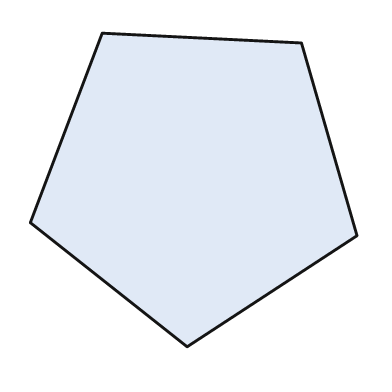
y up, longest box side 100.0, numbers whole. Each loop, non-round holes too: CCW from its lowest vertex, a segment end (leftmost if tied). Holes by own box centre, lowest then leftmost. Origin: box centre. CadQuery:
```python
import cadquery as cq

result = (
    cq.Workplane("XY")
    .moveTo(-2.0, -48.0)
    .lineTo(50.0, -14.0)
    .lineTo(33.0, 45.0)
    .lineTo(-28.0, 48.0)
    .lineTo(-50.0, -10.0)
    .close()
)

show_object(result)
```